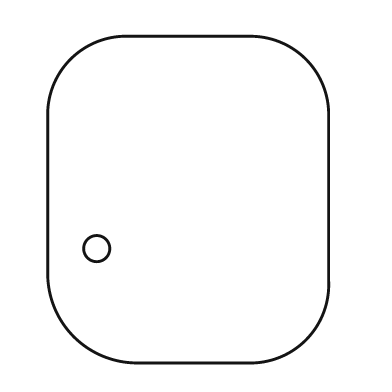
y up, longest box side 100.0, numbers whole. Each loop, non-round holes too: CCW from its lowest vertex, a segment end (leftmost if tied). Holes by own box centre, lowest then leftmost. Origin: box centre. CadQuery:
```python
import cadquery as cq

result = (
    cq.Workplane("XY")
    .moveTo(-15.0, -50.0)
    .lineTo(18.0, -50.0)
    .threePointArc((36.0, -43.0), (43.0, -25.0))
    .lineTo(43.0, 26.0)
    .threePointArc((36.0, 43.0), (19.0, 50.0))
    .lineTo(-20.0, 50.0)
    .threePointArc((-36.0, 43.0), (-43.0, 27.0))
    .lineTo(-43.0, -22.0)
    .threePointArc((-35.0, -42.0), (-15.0, -50.0))
    .close()
    .moveTo(-28.0, -15.0)
    .circle(4.0)
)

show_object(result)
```